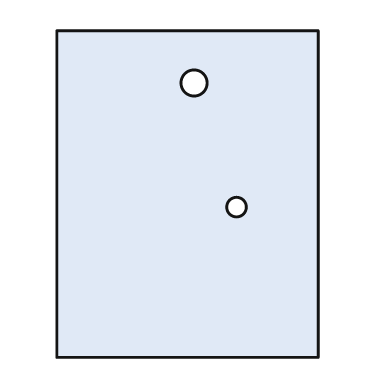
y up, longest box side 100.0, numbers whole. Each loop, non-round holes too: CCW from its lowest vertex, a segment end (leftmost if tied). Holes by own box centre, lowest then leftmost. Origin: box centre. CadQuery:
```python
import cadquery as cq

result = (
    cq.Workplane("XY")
    .moveTo(-40.0, -50.0)
    .lineTo(40.0, -50.0)
    .lineTo(40.0, 50.0)
    .lineTo(-40.0, 50.0)
    .close()
    .moveTo(15.0, -4.0)
    .circle(3.0)
    .moveTo(2.0, 34.0)
    .circle(4.0)
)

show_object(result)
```